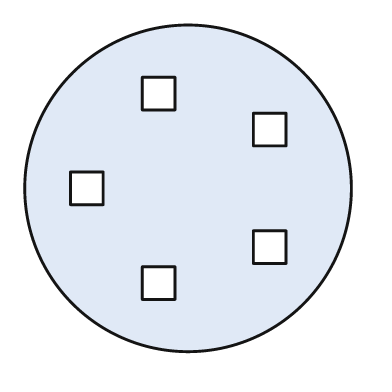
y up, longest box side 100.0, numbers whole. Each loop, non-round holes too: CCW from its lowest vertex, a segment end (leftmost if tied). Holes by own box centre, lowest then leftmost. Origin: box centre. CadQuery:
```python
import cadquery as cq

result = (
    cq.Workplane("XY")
    .moveTo(0.0, 0.0)
    .circle(50.0)
    .moveTo(-14.0, -34.0)
    .lineTo(-4.0, -34.0)
    .lineTo(-4.0, -24.0)
    .lineTo(-14.0, -24.0)
    .close()
    .moveTo(20.0, -23.0)
    .lineTo(30.0, -23.0)
    .lineTo(30.0, -13.0)
    .lineTo(20.0, -13.0)
    .close()
    .moveTo(-36.0, -5.0)
    .lineTo(-26.0, -5.0)
    .lineTo(-26.0, 5.0)
    .lineTo(-36.0, 5.0)
    .close()
    .moveTo(20.0, 13.0)
    .lineTo(30.0, 13.0)
    .lineTo(30.0, 23.0)
    .lineTo(20.0, 23.0)
    .close()
    .moveTo(-14.0, 24.0)
    .lineTo(-4.0, 24.0)
    .lineTo(-4.0, 34.0)
    .lineTo(-14.0, 34.0)
    .close()
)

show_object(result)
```